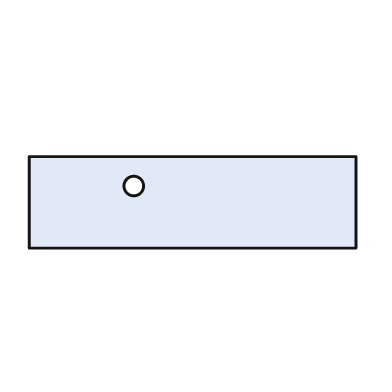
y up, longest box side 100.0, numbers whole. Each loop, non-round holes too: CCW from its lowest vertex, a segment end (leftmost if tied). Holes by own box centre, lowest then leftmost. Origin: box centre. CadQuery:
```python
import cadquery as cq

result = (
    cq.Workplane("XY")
    .moveTo(-50.0, -14.0)
    .lineTo(50.0, -14.0)
    .lineTo(50.0, 14.0)
    .lineTo(-50.0, 14.0)
    .close()
    .moveTo(-18.0, 5.0)
    .circle(3.0)
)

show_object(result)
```